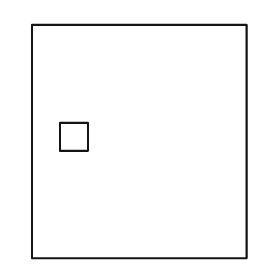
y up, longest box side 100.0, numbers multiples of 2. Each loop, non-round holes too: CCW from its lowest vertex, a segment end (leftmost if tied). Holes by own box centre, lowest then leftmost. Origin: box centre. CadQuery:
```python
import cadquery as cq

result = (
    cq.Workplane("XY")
    .moveTo(-46.0, -50.0)
    .lineTo(46.0, -50.0)
    .lineTo(46.0, 50.0)
    .lineTo(-46.0, 50.0)
    .close()
    .moveTo(-34.0, -4.0)
    .lineTo(-22.0, -4.0)
    .lineTo(-22.0, 8.0)
    .lineTo(-34.0, 8.0)
    .close()
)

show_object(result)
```